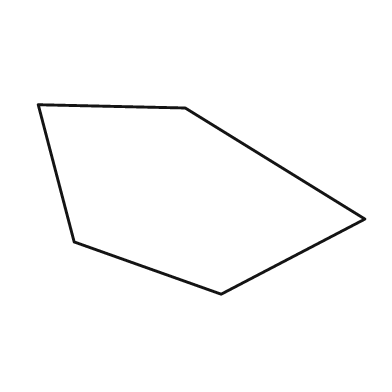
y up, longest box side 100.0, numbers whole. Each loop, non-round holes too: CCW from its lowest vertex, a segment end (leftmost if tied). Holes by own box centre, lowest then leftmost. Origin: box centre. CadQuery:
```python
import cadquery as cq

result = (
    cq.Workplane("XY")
    .moveTo(6.0, -29.0)
    .lineTo(50.0, -6.0)
    .lineTo(-5.0, 28.0)
    .lineTo(-50.0, 29.0)
    .lineTo(-39.0, -13.0)
    .close()
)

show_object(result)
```